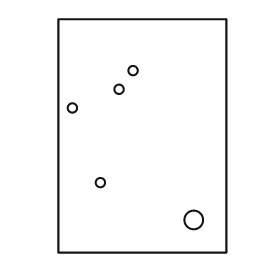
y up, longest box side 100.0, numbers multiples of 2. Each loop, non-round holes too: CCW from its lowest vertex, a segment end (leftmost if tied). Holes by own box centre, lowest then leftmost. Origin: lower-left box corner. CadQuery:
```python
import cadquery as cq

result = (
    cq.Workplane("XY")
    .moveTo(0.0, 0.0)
    .lineTo(72.0, 0.0)
    .lineTo(72.0, 100.0)
    .lineTo(0.0, 100.0)
    .close()
    .moveTo(58.0, 14.0)
    .circle(4.0)
    .moveTo(18.0, 30.0)
    .circle(2.0)
    .moveTo(6.0, 62.0)
    .circle(2.0)
    .moveTo(26.0, 70.0)
    .circle(2.0)
    .moveTo(32.0, 78.0)
    .circle(2.0)
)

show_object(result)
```